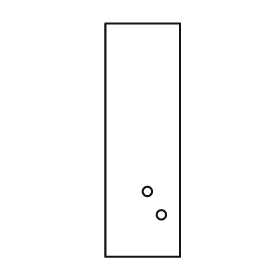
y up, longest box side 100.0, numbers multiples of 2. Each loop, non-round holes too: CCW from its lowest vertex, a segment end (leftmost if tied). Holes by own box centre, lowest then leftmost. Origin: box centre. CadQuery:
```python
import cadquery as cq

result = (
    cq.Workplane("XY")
    .moveTo(-16.0, -50.0)
    .lineTo(16.0, -50.0)
    .lineTo(16.0, 50.0)
    .lineTo(-16.0, 50.0)
    .close()
    .moveTo(8.0, -32.0)
    .circle(2.0)
    .moveTo(2.0, -22.0)
    .circle(2.0)
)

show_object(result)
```